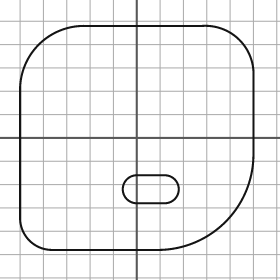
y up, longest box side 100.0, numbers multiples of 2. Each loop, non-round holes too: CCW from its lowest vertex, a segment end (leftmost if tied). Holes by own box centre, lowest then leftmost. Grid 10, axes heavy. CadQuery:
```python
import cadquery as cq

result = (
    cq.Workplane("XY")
    .moveTo(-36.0, -48.0)
    .lineTo(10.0, -48.0)
    .threePointArc((38.0, -36.0), (50.0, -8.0))
    .lineTo(50.0, 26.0)
    .threePointArc((44.0, 42.0), (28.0, 48.0))
    .lineTo(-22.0, 48.0)
    .threePointArc((-42.0, 40.0), (-50.0, 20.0))
    .lineTo(-50.0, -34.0)
    .threePointArc((-46.0, -44.0), (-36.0, -48.0))
    .close()
    .moveTo(0.0, -28.0)
    .lineTo(12.0, -28.0)
    .threePointArc((18.0, -22.0), (12.0, -16.0))
    .lineTo(0.0, -16.0)
    .threePointArc((-6.0, -22.0), (0.0, -28.0))
    .close()
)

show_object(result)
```